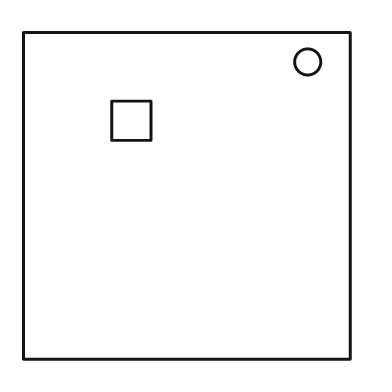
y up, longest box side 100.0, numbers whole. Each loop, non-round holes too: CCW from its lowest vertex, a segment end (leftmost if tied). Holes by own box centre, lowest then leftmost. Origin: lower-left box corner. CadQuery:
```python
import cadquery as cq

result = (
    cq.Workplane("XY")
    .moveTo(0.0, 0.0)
    .lineTo(100.0, 0.0)
    .lineTo(100.0, 100.0)
    .lineTo(0.0, 100.0)
    .close()
    .moveTo(27.0, 67.0)
    .lineTo(39.0, 67.0)
    .lineTo(39.0, 79.0)
    .lineTo(27.0, 79.0)
    .close()
    .moveTo(87.0, 91.0)
    .circle(4.0)
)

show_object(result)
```